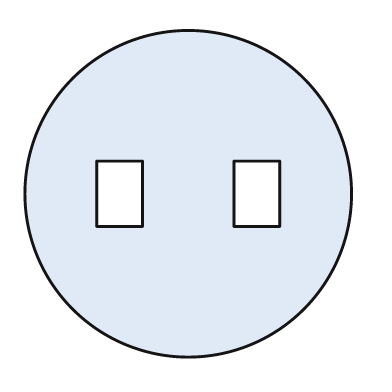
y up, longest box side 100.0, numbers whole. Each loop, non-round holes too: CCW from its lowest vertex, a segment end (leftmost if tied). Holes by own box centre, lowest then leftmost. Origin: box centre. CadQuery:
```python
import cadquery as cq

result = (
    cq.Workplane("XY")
    .moveTo(0.0, 0.0)
    .circle(50.0)
    .moveTo(-28.0, -10.0)
    .lineTo(-14.0, -10.0)
    .lineTo(-14.0, 10.0)
    .lineTo(-28.0, 10.0)
    .close()
    .moveTo(14.0, -10.0)
    .lineTo(28.0, -10.0)
    .lineTo(28.0, 10.0)
    .lineTo(14.0, 10.0)
    .close()
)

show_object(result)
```